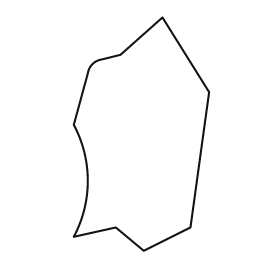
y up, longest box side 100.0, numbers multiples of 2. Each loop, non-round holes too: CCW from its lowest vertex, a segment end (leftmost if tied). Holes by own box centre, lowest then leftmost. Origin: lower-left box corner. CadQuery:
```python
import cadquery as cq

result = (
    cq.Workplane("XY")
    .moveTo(30.0, 0.0)
    .lineTo(50.0, 10.0)
    .lineTo(58.0, 68.0)
    .lineTo(38.0, 100.0)
    .lineTo(20.0, 84.0)
    .lineTo(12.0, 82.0)
    .threePointArc((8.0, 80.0), (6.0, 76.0))
    .lineTo(0.0, 54.0)
    .threePointArc((6.0, 30.0), (0.0, 6.0))
    .lineTo(18.0, 10.0)
    .close()
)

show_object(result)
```